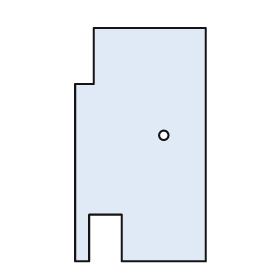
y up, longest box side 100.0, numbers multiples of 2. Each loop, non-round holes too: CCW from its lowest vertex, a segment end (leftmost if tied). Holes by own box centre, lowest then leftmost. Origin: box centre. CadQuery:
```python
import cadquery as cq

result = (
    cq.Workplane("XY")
    .moveTo(-28.0, -50.0)
    .lineTo(-22.0, -50.0)
    .lineTo(-22.0, -30.0)
    .lineTo(-8.0, -30.0)
    .lineTo(-8.0, -50.0)
    .lineTo(28.0, -50.0)
    .lineTo(28.0, 50.0)
    .lineTo(-20.0, 50.0)
    .lineTo(-20.0, 26.0)
    .lineTo(-28.0, 26.0)
    .close()
    .moveTo(10.0, 4.0)
    .circle(2.0)
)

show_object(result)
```